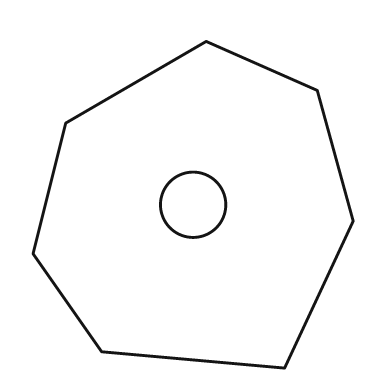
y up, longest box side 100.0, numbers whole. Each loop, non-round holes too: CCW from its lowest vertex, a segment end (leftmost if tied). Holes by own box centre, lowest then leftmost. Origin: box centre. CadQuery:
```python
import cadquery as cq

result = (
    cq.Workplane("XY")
    .moveTo(28.0, -50.0)
    .lineTo(49.0, -5.0)
    .lineTo(38.0, 35.0)
    .lineTo(4.0, 50.0)
    .lineTo(-39.0, 25.0)
    .lineTo(-49.0, -15.0)
    .lineTo(-28.0, -45.0)
    .close()
    .moveTo(0.0, 0.0)
    .circle(10.0)
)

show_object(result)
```